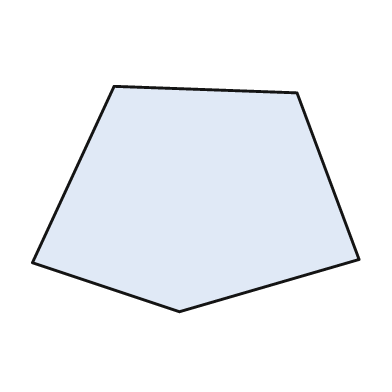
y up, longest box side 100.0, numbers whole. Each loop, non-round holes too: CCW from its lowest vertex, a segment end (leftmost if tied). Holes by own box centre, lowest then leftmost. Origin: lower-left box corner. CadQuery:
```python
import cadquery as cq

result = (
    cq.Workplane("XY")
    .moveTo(45.0, 0.0)
    .lineTo(100.0, 16.0)
    .lineTo(81.0, 67.0)
    .lineTo(25.0, 69.0)
    .lineTo(0.0, 15.0)
    .close()
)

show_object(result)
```